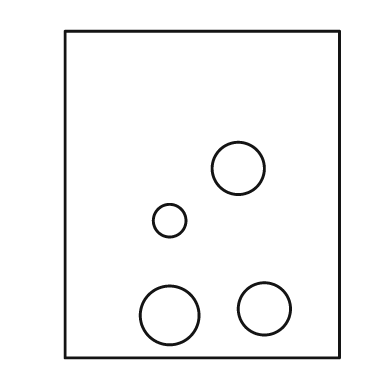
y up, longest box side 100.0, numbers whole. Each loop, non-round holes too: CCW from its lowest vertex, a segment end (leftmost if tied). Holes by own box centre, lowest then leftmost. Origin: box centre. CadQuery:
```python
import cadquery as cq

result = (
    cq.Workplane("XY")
    .moveTo(-42.0, -50.0)
    .lineTo(42.0, -50.0)
    .lineTo(42.0, 50.0)
    .lineTo(-42.0, 50.0)
    .close()
    .moveTo(-10.0, -37.0)
    .circle(9.0)
    .moveTo(19.0, -35.0)
    .circle(8.0)
    .moveTo(-10.0, -8.0)
    .circle(5.0)
    .moveTo(11.0, 8.0)
    .circle(8.0)
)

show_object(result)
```